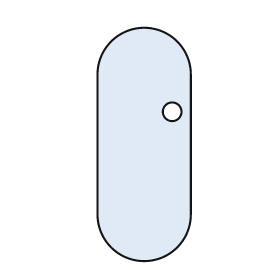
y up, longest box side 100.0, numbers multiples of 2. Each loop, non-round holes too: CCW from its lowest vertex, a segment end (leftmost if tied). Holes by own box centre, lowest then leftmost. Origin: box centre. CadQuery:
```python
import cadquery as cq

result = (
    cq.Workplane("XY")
    .moveTo(-20.0, -30.0)
    .threePointArc((0.0, -50.0), (20.0, -30.0))
    .lineTo(20.0, 30.0)
    .threePointArc((0.0, 50.0), (-20.0, 30.0))
    .close()
    .moveTo(12.0, 14.0)
    .circle(4.0)
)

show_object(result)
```